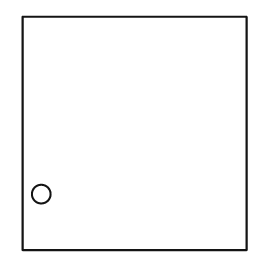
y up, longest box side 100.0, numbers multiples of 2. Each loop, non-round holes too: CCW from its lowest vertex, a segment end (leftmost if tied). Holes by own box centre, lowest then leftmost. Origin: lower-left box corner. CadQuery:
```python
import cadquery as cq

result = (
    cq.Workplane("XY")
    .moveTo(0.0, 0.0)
    .lineTo(96.0, 0.0)
    .lineTo(96.0, 100.0)
    .lineTo(0.0, 100.0)
    .close()
    .moveTo(8.0, 24.0)
    .circle(4.0)
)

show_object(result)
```